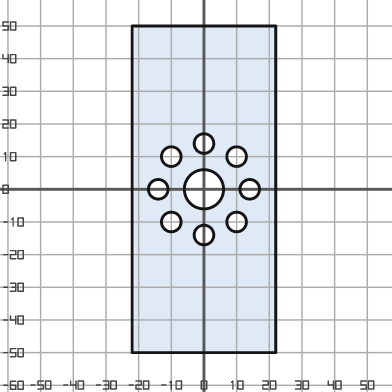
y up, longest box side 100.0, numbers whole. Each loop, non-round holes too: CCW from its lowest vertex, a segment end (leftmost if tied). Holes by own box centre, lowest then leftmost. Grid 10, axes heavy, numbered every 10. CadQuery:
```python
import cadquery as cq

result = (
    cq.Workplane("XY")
    .moveTo(-22.0, -50.0)
    .lineTo(22.0, -50.0)
    .lineTo(22.0, 50.0)
    .lineTo(-22.0, 50.0)
    .close()
    .moveTo(0.0, -14.0)
    .circle(3.0)
    .moveTo(-10.0, -10.0)
    .circle(3.0)
    .moveTo(10.0, -10.0)
    .circle(3.0)
    .moveTo(-14.0, 0.0)
    .circle(3.0)
    .moveTo(0.0, 0.0)
    .circle(6.0)
    .moveTo(14.0, 0.0)
    .circle(3.0)
    .moveTo(-10.0, 10.0)
    .circle(3.0)
    .moveTo(10.0, 10.0)
    .circle(3.0)
    .moveTo(0.0, 14.0)
    .circle(3.0)
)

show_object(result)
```